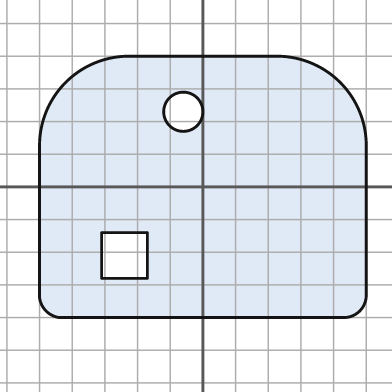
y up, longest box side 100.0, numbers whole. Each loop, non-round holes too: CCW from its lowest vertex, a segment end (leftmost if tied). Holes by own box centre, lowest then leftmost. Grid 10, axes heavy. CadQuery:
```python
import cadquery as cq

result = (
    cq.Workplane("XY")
    .moveTo(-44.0, -40.0)
    .lineTo(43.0, -40.0)
    .threePointArc((48.0, -38.0), (50.0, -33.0))
    .lineTo(50.0, 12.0)
    .threePointArc((42.0, 32.0), (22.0, 40.0))
    .lineTo(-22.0, 40.0)
    .threePointArc((-42.0, 32.0), (-50.0, 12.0))
    .lineTo(-50.0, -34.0)
    .threePointArc((-48.0, -38.0), (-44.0, -40.0))
    .close()
    .moveTo(-31.0, -28.0)
    .lineTo(-17.0, -28.0)
    .lineTo(-17.0, -14.0)
    .lineTo(-31.0, -14.0)
    .close()
    .moveTo(-6.0, 23.0)
    .circle(6.0)
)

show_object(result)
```